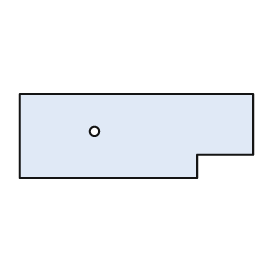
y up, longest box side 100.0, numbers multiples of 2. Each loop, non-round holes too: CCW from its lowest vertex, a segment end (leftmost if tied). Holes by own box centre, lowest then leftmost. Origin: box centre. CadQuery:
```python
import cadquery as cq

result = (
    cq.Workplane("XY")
    .moveTo(-50.0, -18.0)
    .lineTo(26.0, -18.0)
    .lineTo(26.0, -8.0)
    .lineTo(50.0, -8.0)
    .lineTo(50.0, 18.0)
    .lineTo(-50.0, 18.0)
    .close()
    .moveTo(-18.0, 2.0)
    .circle(2.0)
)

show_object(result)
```